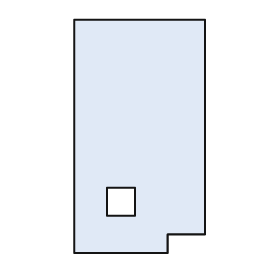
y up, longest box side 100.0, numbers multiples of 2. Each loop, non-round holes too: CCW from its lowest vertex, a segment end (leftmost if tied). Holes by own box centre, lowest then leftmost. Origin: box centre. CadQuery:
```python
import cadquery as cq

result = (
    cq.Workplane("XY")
    .moveTo(-28.0, -50.0)
    .lineTo(12.0, -50.0)
    .lineTo(12.0, -42.0)
    .lineTo(28.0, -42.0)
    .lineTo(28.0, 50.0)
    .lineTo(-28.0, 50.0)
    .close()
    .moveTo(-14.0, -34.0)
    .lineTo(-2.0, -34.0)
    .lineTo(-2.0, -22.0)
    .lineTo(-14.0, -22.0)
    .close()
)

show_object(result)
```